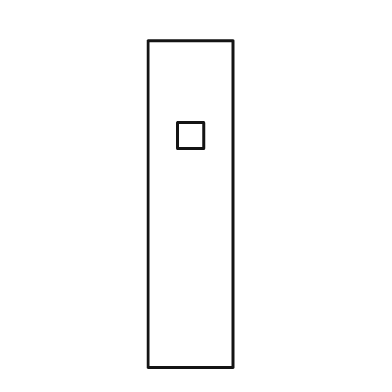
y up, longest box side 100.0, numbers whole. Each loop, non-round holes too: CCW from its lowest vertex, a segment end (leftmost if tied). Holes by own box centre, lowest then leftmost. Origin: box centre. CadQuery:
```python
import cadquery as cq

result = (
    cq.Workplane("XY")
    .moveTo(-13.0, -50.0)
    .lineTo(13.0, -50.0)
    .lineTo(13.0, 50.0)
    .lineTo(-13.0, 50.0)
    .close()
    .moveTo(-4.0, 17.0)
    .lineTo(4.0, 17.0)
    .lineTo(4.0, 25.0)
    .lineTo(-4.0, 25.0)
    .close()
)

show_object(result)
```